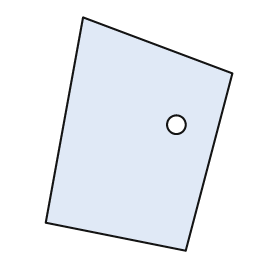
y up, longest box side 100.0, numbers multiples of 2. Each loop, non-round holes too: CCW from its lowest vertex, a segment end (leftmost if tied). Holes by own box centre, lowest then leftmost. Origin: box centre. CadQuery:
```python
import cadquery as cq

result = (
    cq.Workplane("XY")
    .moveTo(20.0, -50.0)
    .lineTo(40.0, 26.0)
    .lineTo(-24.0, 50.0)
    .lineTo(-40.0, -38.0)
    .close()
    .moveTo(16.0, 4.0)
    .circle(4.0)
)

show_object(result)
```